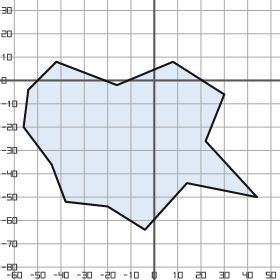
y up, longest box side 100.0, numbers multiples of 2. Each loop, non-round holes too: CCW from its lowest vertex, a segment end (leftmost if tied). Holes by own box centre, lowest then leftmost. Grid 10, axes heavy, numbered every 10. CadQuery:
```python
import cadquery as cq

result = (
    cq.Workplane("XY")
    .moveTo(-4.0, -64.0)
    .lineTo(14.0, -44.0)
    .lineTo(44.0, -50.0)
    .lineTo(22.0, -26.0)
    .lineTo(30.0, -6.0)
    .lineTo(8.0, 8.0)
    .lineTo(-16.0, -2.0)
    .lineTo(-42.0, 8.0)
    .lineTo(-54.0, -4.0)
    .lineTo(-56.0, -20.0)
    .lineTo(-44.0, -36.0)
    .lineTo(-38.0, -52.0)
    .lineTo(-20.0, -54.0)
    .close()
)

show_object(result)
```